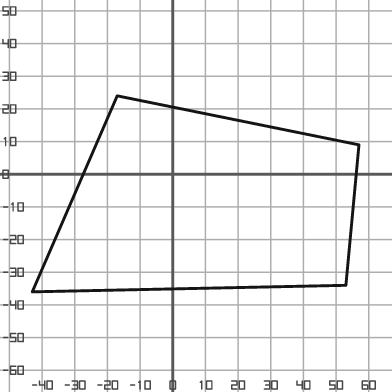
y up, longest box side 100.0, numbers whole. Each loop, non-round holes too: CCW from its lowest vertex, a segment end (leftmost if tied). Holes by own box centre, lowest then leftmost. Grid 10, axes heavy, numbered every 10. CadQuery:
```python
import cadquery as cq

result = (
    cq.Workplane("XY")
    .moveTo(-43.0, -36.0)
    .lineTo(53.0, -34.0)
    .lineTo(57.0, 9.0)
    .lineTo(-17.0, 24.0)
    .close()
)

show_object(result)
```